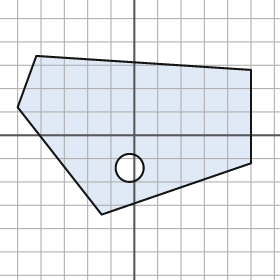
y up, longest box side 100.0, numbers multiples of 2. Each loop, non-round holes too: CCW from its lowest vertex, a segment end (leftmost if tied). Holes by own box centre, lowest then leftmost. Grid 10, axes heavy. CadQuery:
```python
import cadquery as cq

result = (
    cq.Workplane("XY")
    .moveTo(-14.0, -34.0)
    .lineTo(50.0, -12.0)
    .lineTo(50.0, 28.0)
    .lineTo(-42.0, 34.0)
    .lineTo(-50.0, 12.0)
    .close()
    .moveTo(-2.0, -14.0)
    .circle(6.0)
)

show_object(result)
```